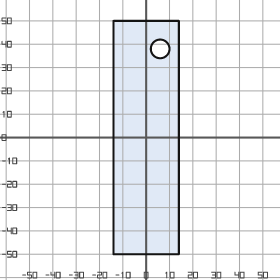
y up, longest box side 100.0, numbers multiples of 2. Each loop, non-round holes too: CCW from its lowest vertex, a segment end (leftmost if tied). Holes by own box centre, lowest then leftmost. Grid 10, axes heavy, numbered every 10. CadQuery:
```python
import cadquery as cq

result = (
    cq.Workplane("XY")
    .moveTo(-14.0, -50.0)
    .lineTo(14.0, -50.0)
    .lineTo(14.0, 50.0)
    .lineTo(-14.0, 50.0)
    .close()
    .moveTo(6.0, 38.0)
    .circle(4.0)
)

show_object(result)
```